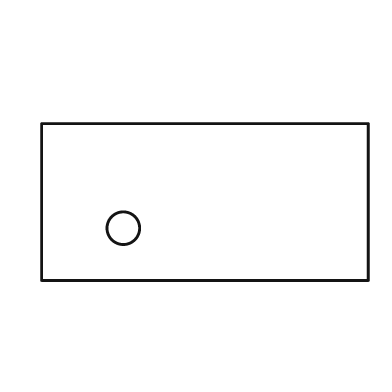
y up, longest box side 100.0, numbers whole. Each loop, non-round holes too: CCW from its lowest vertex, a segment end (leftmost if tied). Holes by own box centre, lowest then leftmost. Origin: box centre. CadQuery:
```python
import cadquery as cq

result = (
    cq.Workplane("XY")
    .moveTo(-50.0, -24.0)
    .lineTo(50.0, -24.0)
    .lineTo(50.0, 24.0)
    .lineTo(-50.0, 24.0)
    .close()
    .moveTo(-25.0, -8.0)
    .circle(5.0)
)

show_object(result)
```